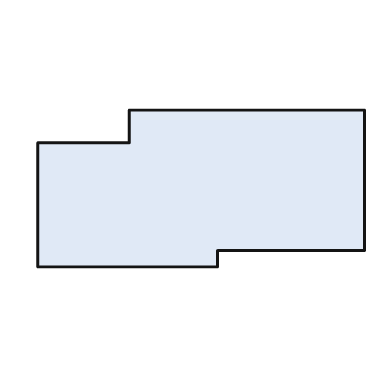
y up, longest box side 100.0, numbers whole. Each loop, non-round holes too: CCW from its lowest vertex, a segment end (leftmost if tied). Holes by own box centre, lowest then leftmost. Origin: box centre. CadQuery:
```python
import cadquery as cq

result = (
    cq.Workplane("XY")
    .moveTo(-50.0, -24.0)
    .lineTo(5.0, -24.0)
    .lineTo(5.0, -19.0)
    .lineTo(50.0, -19.0)
    .lineTo(50.0, 24.0)
    .lineTo(-22.0, 24.0)
    .lineTo(-22.0, 14.0)
    .lineTo(-50.0, 14.0)
    .close()
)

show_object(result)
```